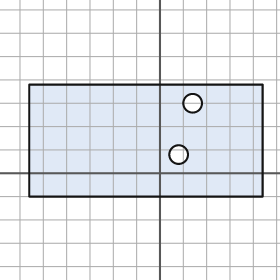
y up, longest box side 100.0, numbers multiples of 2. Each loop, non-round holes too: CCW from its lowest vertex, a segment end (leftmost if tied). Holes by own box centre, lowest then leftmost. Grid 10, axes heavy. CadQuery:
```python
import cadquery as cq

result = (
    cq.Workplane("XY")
    .moveTo(-56.0, -10.0)
    .lineTo(44.0, -10.0)
    .lineTo(44.0, 38.0)
    .lineTo(-56.0, 38.0)
    .close()
    .moveTo(8.0, 8.0)
    .circle(4.0)
    .moveTo(14.0, 30.0)
    .circle(4.0)
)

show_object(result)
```